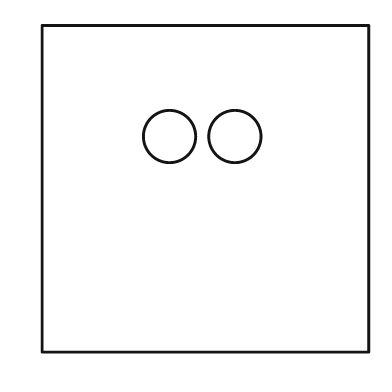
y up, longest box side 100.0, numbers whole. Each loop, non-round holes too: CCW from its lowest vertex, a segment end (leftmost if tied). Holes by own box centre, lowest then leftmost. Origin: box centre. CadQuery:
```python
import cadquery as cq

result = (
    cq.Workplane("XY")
    .moveTo(-50.0, -50.0)
    .lineTo(50.0, -50.0)
    .lineTo(50.0, 50.0)
    .lineTo(-50.0, 50.0)
    .close()
    .moveTo(-11.0, 16.0)
    .circle(8.0)
    .moveTo(9.0, 16.0)
    .circle(8.0)
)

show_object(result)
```